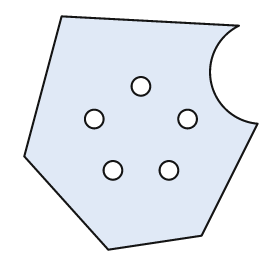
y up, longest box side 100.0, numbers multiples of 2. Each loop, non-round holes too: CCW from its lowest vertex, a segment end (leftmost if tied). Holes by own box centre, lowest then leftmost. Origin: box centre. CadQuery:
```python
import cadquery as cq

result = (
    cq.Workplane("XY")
    .moveTo(-14.0, -50.0)
    .lineTo(26.0, -44.0)
    .lineTo(50.0, 4.0)
    .threePointArc((30.0, 22.0), (42.0, 46.0))
    .lineTo(-34.0, 50.0)
    .lineTo(-50.0, -10.0)
    .close()
    .moveTo(-12.0, -16.0)
    .circle(4.0)
    .moveTo(12.0, -16.0)
    .circle(4.0)
    .moveTo(-20.0, 6.0)
    .circle(4.0)
    .moveTo(20.0, 6.0)
    .circle(4.0)
    .moveTo(0.0, 20.0)
    .circle(4.0)
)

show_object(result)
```